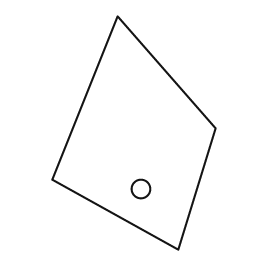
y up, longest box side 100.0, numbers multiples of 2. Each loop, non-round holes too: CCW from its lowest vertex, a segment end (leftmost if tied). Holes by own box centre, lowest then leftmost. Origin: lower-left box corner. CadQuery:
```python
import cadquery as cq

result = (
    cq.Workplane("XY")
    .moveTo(54.0, 0.0)
    .lineTo(70.0, 52.0)
    .lineTo(28.0, 100.0)
    .lineTo(0.0, 30.0)
    .close()
    .moveTo(38.0, 26.0)
    .circle(4.0)
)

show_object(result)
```